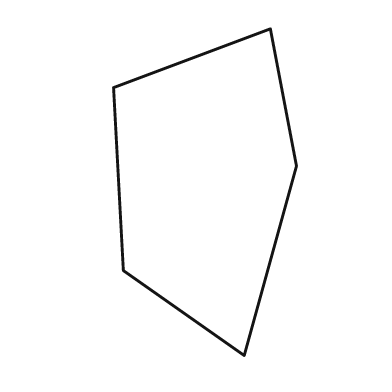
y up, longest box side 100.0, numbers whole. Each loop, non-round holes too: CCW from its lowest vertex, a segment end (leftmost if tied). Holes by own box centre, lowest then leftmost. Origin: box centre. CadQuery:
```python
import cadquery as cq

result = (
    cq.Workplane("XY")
    .moveTo(12.0, -50.0)
    .lineTo(28.0, 8.0)
    .lineTo(20.0, 50.0)
    .lineTo(-28.0, 32.0)
    .lineTo(-25.0, -24.0)
    .close()
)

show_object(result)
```